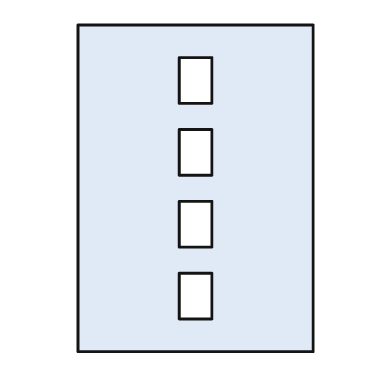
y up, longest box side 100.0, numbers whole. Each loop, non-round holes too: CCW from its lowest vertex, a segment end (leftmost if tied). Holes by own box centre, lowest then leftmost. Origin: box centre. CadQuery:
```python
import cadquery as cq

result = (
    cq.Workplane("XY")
    .moveTo(-36.0, -50.0)
    .lineTo(36.0, -50.0)
    .lineTo(36.0, 50.0)
    .lineTo(-36.0, 50.0)
    .close()
    .moveTo(-5.0, -40.0)
    .lineTo(5.0, -40.0)
    .lineTo(5.0, -26.0)
    .lineTo(-5.0, -26.0)
    .close()
    .moveTo(-5.0, -18.0)
    .lineTo(5.0, -18.0)
    .lineTo(5.0, -4.0)
    .lineTo(-5.0, -4.0)
    .close()
    .moveTo(-5.0, 4.0)
    .lineTo(5.0, 4.0)
    .lineTo(5.0, 18.0)
    .lineTo(-5.0, 18.0)
    .close()
    .moveTo(-5.0, 26.0)
    .lineTo(5.0, 26.0)
    .lineTo(5.0, 40.0)
    .lineTo(-5.0, 40.0)
    .close()
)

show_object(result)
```